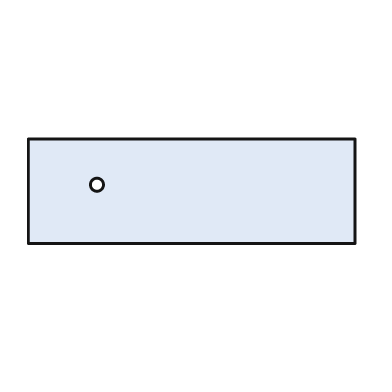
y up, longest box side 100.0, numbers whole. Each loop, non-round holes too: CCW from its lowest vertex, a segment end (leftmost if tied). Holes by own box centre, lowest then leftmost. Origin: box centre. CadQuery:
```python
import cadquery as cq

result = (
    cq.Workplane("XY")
    .moveTo(-50.0, -16.0)
    .lineTo(50.0, -16.0)
    .lineTo(50.0, 16.0)
    .lineTo(-50.0, 16.0)
    .close()
    .moveTo(-29.0, 2.0)
    .circle(2.0)
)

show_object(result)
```